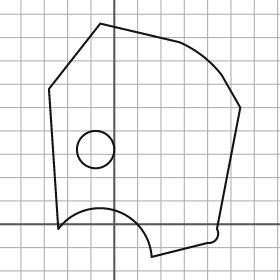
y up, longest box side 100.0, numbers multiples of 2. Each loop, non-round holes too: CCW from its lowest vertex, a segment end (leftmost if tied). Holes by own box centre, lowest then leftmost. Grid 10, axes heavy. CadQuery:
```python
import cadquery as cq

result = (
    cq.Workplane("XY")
    .moveTo(16.0, -14.0)
    .lineTo(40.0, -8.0)
    .threePointArc((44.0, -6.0), (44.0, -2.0))
    .lineTo(54.0, 50.0)
    .lineTo(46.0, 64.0)
    .threePointArc((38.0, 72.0), (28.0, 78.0))
    .lineTo(-6.0, 86.0)
    .lineTo(-28.0, 58.0)
    .lineTo(-24.0, -2.0)
    .threePointArc((0.0, 6.0), (16.0, -14.0))
    .close()
    .moveTo(-8.0, 32.0)
    .circle(8.0)
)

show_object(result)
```